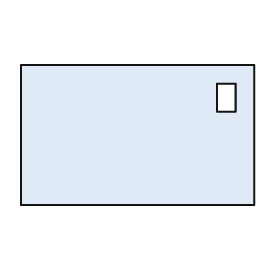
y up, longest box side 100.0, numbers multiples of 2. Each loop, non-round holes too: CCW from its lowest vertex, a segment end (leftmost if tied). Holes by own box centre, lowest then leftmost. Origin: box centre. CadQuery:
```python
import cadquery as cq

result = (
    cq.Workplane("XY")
    .moveTo(-50.0, -30.0)
    .lineTo(50.0, -30.0)
    .lineTo(50.0, 30.0)
    .lineTo(-50.0, 30.0)
    .close()
    .moveTo(34.0, 10.0)
    .lineTo(42.0, 10.0)
    .lineTo(42.0, 22.0)
    .lineTo(34.0, 22.0)
    .close()
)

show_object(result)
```